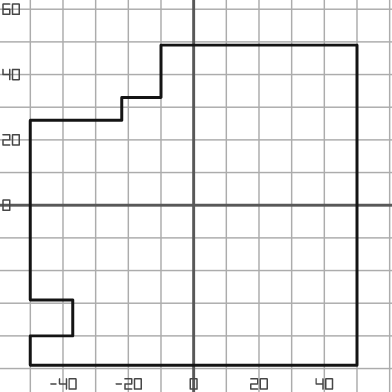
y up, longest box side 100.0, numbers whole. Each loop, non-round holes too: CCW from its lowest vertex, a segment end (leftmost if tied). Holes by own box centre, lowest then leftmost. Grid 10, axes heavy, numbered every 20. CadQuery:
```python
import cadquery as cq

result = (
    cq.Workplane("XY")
    .moveTo(-50.0, -49.0)
    .lineTo(50.0, -49.0)
    .lineTo(50.0, 49.0)
    .lineTo(-10.0, 49.0)
    .lineTo(-10.0, 33.0)
    .lineTo(-22.0, 33.0)
    .lineTo(-22.0, 26.0)
    .lineTo(-50.0, 26.0)
    .lineTo(-50.0, -29.0)
    .lineTo(-37.0, -29.0)
    .lineTo(-37.0, -40.0)
    .lineTo(-50.0, -40.0)
    .close()
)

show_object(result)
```